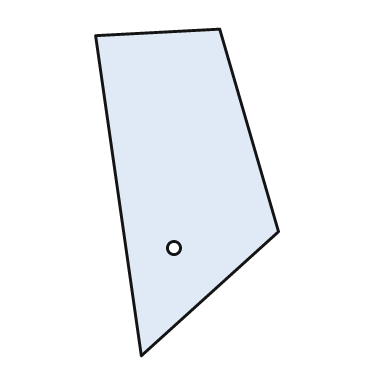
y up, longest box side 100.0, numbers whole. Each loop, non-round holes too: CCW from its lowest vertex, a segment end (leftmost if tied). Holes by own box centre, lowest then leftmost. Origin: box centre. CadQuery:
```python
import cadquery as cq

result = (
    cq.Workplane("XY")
    .moveTo(-14.0, -50.0)
    .lineTo(28.0, -12.0)
    .lineTo(10.0, 50.0)
    .lineTo(-28.0, 48.0)
    .close()
    .moveTo(-4.0, -17.0)
    .circle(2.0)
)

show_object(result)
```